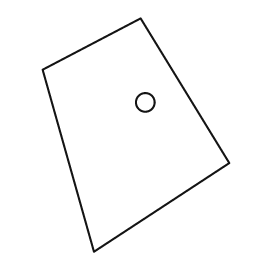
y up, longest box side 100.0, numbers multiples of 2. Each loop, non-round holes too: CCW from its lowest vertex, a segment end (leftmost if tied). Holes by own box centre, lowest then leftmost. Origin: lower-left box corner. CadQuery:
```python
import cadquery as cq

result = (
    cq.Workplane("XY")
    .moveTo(22.0, 0.0)
    .lineTo(80.0, 38.0)
    .lineTo(42.0, 100.0)
    .lineTo(0.0, 78.0)
    .close()
    .moveTo(44.0, 64.0)
    .circle(4.0)
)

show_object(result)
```